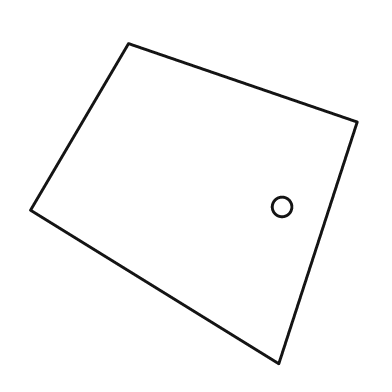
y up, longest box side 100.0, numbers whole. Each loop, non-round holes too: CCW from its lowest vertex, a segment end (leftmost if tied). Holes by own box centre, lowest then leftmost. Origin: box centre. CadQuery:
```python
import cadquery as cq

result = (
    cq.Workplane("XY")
    .moveTo(26.0, -49.0)
    .lineTo(50.0, 25.0)
    .lineTo(-20.0, 49.0)
    .lineTo(-50.0, -2.0)
    .close()
    .moveTo(27.0, -1.0)
    .circle(3.0)
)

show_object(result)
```